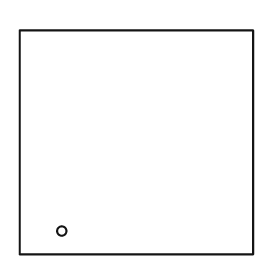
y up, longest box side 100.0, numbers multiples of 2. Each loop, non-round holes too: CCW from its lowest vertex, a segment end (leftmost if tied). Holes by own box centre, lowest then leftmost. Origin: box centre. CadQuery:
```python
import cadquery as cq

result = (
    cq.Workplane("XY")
    .moveTo(-50.0, -48.0)
    .lineTo(50.0, -48.0)
    .lineTo(50.0, 48.0)
    .lineTo(-50.0, 48.0)
    .close()
    .moveTo(-32.0, -38.0)
    .circle(2.0)
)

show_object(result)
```